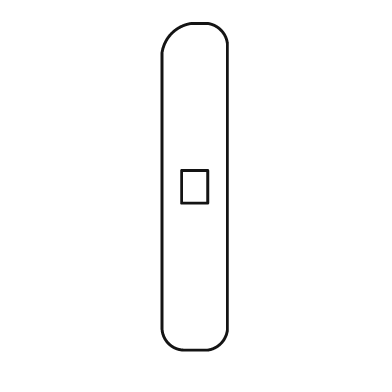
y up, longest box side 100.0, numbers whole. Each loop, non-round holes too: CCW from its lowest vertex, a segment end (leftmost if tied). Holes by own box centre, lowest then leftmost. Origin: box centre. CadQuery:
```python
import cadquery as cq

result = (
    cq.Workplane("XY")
    .moveTo(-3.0, -50.0)
    .lineTo(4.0, -50.0)
    .threePointArc((8.0, -48.0), (10.0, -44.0))
    .lineTo(10.0, 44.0)
    .threePointArc((8.0, 48.0), (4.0, 50.0))
    .lineTo(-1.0, 50.0)
    .threePointArc((-7.0, 47.0), (-10.0, 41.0))
    .lineTo(-10.0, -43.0)
    .threePointArc((-8.0, -48.0), (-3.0, -50.0))
    .close()
    .moveTo(-4.0, -5.0)
    .lineTo(4.0, -5.0)
    .lineTo(4.0, 5.0)
    .lineTo(-4.0, 5.0)
    .close()
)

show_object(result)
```